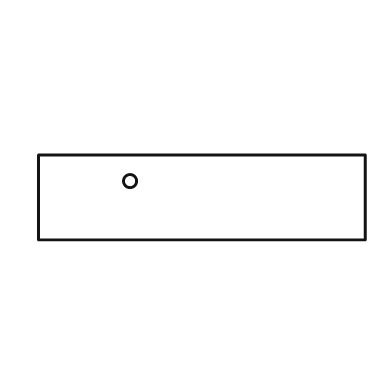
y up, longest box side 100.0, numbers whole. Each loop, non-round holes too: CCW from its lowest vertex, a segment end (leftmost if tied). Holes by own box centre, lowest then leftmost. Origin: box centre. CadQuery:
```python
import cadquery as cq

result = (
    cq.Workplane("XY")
    .moveTo(-50.0, -13.0)
    .lineTo(50.0, -13.0)
    .lineTo(50.0, 13.0)
    .lineTo(-50.0, 13.0)
    .close()
    .moveTo(-22.0, 5.0)
    .circle(2.0)
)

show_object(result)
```